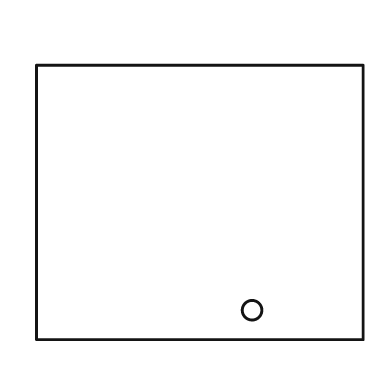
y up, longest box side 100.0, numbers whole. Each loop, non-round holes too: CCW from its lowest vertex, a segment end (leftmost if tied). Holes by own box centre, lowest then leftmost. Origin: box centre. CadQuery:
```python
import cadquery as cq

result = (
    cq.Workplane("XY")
    .moveTo(-50.0, -42.0)
    .lineTo(50.0, -42.0)
    .lineTo(50.0, 42.0)
    .lineTo(-50.0, 42.0)
    .close()
    .moveTo(16.0, -33.0)
    .circle(3.0)
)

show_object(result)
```